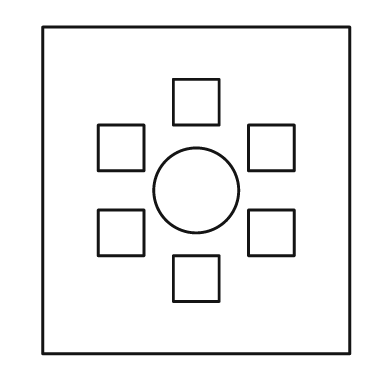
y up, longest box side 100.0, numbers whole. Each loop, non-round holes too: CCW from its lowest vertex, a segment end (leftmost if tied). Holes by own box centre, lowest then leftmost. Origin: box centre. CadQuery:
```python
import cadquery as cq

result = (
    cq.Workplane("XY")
    .moveTo(-47.0, -50.0)
    .lineTo(47.0, -50.0)
    .lineTo(47.0, 50.0)
    .lineTo(-47.0, 50.0)
    .close()
    .moveTo(-7.0, -34.0)
    .lineTo(7.0, -34.0)
    .lineTo(7.0, -20.0)
    .lineTo(-7.0, -20.0)
    .close()
    .moveTo(-30.0, -20.0)
    .lineTo(-16.0, -20.0)
    .lineTo(-16.0, -6.0)
    .lineTo(-30.0, -6.0)
    .close()
    .moveTo(16.0, -20.0)
    .lineTo(30.0, -20.0)
    .lineTo(30.0, -6.0)
    .lineTo(16.0, -6.0)
    .close()
    .moveTo(0.0, 0.0)
    .circle(13.0)
    .moveTo(-30.0, 6.0)
    .lineTo(-16.0, 6.0)
    .lineTo(-16.0, 20.0)
    .lineTo(-30.0, 20.0)
    .close()
    .moveTo(16.0, 6.0)
    .lineTo(30.0, 6.0)
    .lineTo(30.0, 20.0)
    .lineTo(16.0, 20.0)
    .close()
    .moveTo(-7.0, 20.0)
    .lineTo(7.0, 20.0)
    .lineTo(7.0, 34.0)
    .lineTo(-7.0, 34.0)
    .close()
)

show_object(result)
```